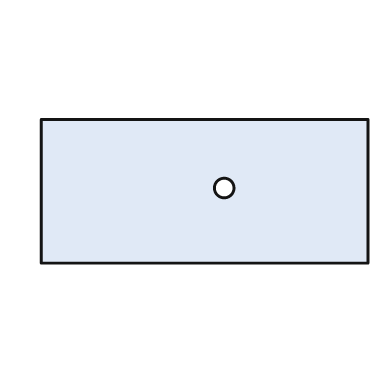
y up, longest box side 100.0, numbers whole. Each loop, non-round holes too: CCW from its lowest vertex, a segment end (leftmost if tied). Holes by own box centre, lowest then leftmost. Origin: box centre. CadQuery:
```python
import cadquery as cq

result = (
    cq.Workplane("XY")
    .moveTo(-50.0, -22.0)
    .lineTo(50.0, -22.0)
    .lineTo(50.0, 22.0)
    .lineTo(-50.0, 22.0)
    .close()
    .moveTo(6.0, 1.0)
    .circle(3.0)
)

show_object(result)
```